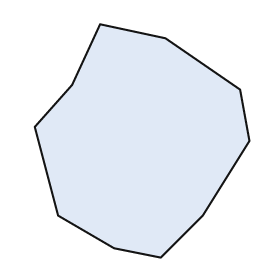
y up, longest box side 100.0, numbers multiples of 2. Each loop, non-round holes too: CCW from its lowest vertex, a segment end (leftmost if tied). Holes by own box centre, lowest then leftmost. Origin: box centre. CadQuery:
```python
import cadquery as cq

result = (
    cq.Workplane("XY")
    .moveTo(8.0, -50.0)
    .lineTo(26.0, -32.0)
    .lineTo(46.0, 0.0)
    .lineTo(42.0, 22.0)
    .lineTo(10.0, 44.0)
    .lineTo(-18.0, 50.0)
    .lineTo(-30.0, 24.0)
    .lineTo(-46.0, 6.0)
    .lineTo(-36.0, -32.0)
    .lineTo(-12.0, -46.0)
    .close()
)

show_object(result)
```